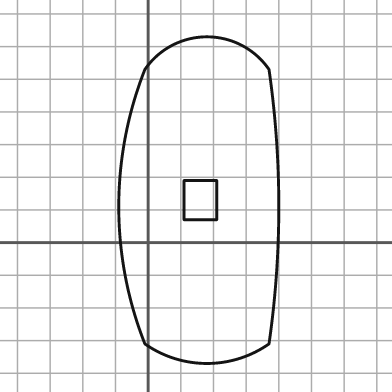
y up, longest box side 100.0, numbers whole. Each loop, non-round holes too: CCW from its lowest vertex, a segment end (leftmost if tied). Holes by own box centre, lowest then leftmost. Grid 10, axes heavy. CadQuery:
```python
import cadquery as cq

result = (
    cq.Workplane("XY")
    .moveTo(-1.0, -31.0)
    .threePointArc((18.0, -37.0), (37.0, -31.0))
    .threePointArc((40.0, 11.0), (37.0, 53.0))
    .threePointArc((18.0, 63.0), (-1.0, 53.0))
    .threePointArc((-9.0, 11.0), (-1.0, -31.0))
    .close()
    .moveTo(11.0, 7.0)
    .lineTo(21.0, 7.0)
    .lineTo(21.0, 19.0)
    .lineTo(11.0, 19.0)
    .close()
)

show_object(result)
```